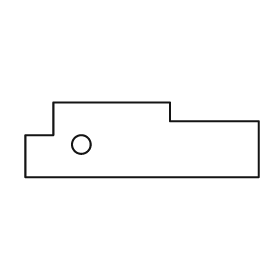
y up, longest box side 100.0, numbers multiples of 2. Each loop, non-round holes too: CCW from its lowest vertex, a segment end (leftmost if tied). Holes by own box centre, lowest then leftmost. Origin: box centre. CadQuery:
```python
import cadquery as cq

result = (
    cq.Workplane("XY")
    .moveTo(-50.0, -16.0)
    .lineTo(50.0, -16.0)
    .lineTo(50.0, 8.0)
    .lineTo(12.0, 8.0)
    .lineTo(12.0, 16.0)
    .lineTo(-38.0, 16.0)
    .lineTo(-38.0, 2.0)
    .lineTo(-50.0, 2.0)
    .close()
    .moveTo(-26.0, -2.0)
    .circle(4.0)
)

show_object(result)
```